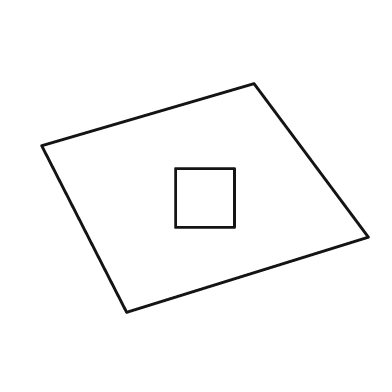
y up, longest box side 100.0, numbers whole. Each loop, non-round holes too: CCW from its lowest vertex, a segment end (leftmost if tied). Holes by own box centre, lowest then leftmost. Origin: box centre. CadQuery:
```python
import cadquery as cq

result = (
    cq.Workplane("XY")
    .moveTo(-24.0, -35.0)
    .lineTo(50.0, -12.0)
    .lineTo(15.0, 35.0)
    .lineTo(-50.0, 16.0)
    .close()
    .moveTo(-9.0, -9.0)
    .lineTo(9.0, -9.0)
    .lineTo(9.0, 9.0)
    .lineTo(-9.0, 9.0)
    .close()
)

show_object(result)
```